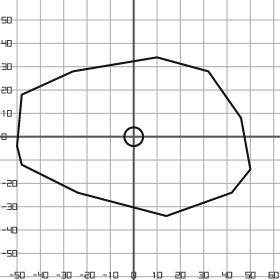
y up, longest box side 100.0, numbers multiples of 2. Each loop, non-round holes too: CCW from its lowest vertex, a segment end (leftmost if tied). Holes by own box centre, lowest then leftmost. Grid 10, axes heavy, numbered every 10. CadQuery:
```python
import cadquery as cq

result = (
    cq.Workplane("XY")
    .moveTo(14.0, -34.0)
    .lineTo(42.0, -24.0)
    .lineTo(50.0, -14.0)
    .lineTo(46.0, 8.0)
    .lineTo(32.0, 28.0)
    .lineTo(10.0, 34.0)
    .lineTo(-26.0, 28.0)
    .lineTo(-48.0, 18.0)
    .lineTo(-50.0, -4.0)
    .lineTo(-48.0, -12.0)
    .lineTo(-24.0, -24.0)
    .close()
    .moveTo(0.0, 0.0)
    .circle(4.0)
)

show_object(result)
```